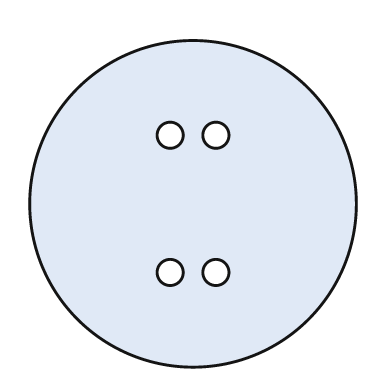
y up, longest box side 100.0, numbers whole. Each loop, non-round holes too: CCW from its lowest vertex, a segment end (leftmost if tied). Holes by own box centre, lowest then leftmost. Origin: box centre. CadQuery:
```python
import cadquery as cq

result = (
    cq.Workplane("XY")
    .moveTo(0.0, 0.0)
    .circle(50.0)
    .moveTo(-7.0, -21.0)
    .circle(4.0)
    .moveTo(7.0, -21.0)
    .circle(4.0)
    .moveTo(-7.0, 21.0)
    .circle(4.0)
    .moveTo(7.0, 21.0)
    .circle(4.0)
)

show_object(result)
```